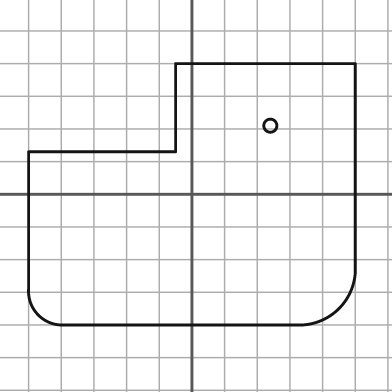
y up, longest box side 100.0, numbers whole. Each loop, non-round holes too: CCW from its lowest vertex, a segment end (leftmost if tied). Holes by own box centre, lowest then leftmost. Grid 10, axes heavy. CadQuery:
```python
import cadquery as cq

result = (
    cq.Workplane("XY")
    .moveTo(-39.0, -40.0)
    .lineTo(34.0, -40.0)
    .threePointArc((45.0, -35.0), (50.0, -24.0))
    .lineTo(50.0, 40.0)
    .lineTo(-5.0, 40.0)
    .lineTo(-5.0, 13.0)
    .lineTo(-50.0, 13.0)
    .lineTo(-50.0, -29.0)
    .threePointArc((-47.0, -37.0), (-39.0, -40.0))
    .close()
    .moveTo(24.0, 21.0)
    .circle(2.0)
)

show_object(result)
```